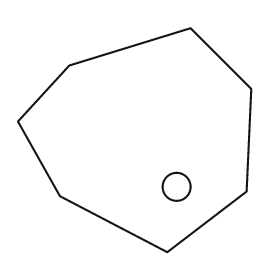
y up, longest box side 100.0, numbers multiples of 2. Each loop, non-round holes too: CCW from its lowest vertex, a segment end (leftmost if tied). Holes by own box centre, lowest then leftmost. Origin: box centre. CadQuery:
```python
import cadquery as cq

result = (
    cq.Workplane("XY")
    .moveTo(14.0, -48.0)
    .lineTo(48.0, -22.0)
    .lineTo(50.0, 22.0)
    .lineTo(24.0, 48.0)
    .lineTo(-28.0, 32.0)
    .lineTo(-50.0, 8.0)
    .lineTo(-32.0, -24.0)
    .close()
    .moveTo(18.0, -20.0)
    .circle(6.0)
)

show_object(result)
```